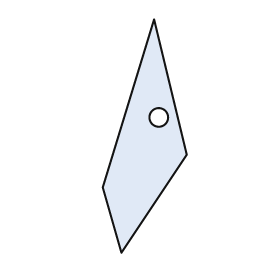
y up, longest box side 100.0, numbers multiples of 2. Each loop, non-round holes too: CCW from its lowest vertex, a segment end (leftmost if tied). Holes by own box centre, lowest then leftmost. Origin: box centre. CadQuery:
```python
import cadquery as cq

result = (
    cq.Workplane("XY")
    .moveTo(-10.0, -50.0)
    .lineTo(18.0, -8.0)
    .lineTo(4.0, 50.0)
    .lineTo(-18.0, -22.0)
    .close()
    .moveTo(6.0, 8.0)
    .circle(4.0)
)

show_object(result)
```